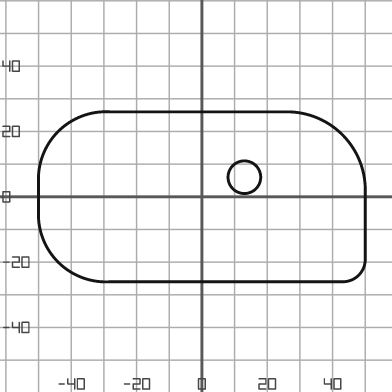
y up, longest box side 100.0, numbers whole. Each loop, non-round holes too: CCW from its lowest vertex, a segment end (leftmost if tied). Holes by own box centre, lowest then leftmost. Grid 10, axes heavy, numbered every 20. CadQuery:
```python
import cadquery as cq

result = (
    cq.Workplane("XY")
    .moveTo(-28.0, -26.0)
    .lineTo(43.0, -26.0)
    .threePointArc((48.0, -24.0), (50.0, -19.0))
    .lineTo(50.0, 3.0)
    .threePointArc((43.0, 19.0), (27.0, 26.0))
    .lineTo(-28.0, 26.0)
    .threePointArc((-44.0, 20.0), (-50.0, 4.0))
    .lineTo(-50.0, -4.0)
    .threePointArc((-44.0, -20.0), (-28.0, -26.0))
    .close()
    .moveTo(13.0, 6.0)
    .circle(5.0)
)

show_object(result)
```